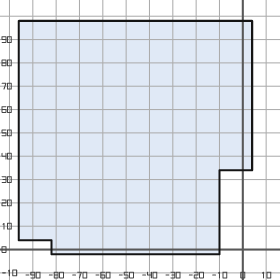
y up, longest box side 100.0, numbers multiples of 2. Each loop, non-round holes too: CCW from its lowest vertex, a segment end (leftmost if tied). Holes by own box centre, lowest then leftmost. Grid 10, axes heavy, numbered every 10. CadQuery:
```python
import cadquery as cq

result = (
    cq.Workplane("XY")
    .moveTo(-82.0, -2.0)
    .lineTo(-10.0, -2.0)
    .lineTo(-10.0, 34.0)
    .lineTo(4.0, 34.0)
    .lineTo(4.0, 98.0)
    .lineTo(-96.0, 98.0)
    .lineTo(-96.0, 4.0)
    .lineTo(-82.0, 4.0)
    .close()
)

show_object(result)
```